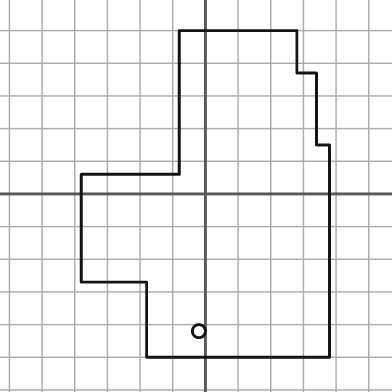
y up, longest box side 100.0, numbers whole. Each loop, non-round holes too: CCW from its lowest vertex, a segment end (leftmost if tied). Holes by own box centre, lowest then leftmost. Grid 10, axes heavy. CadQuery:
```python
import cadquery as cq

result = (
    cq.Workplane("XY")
    .moveTo(-18.0, -50.0)
    .lineTo(38.0, -50.0)
    .lineTo(38.0, 15.0)
    .lineTo(34.0, 15.0)
    .lineTo(34.0, 37.0)
    .lineTo(28.0, 37.0)
    .lineTo(28.0, 50.0)
    .lineTo(-8.0, 50.0)
    .lineTo(-8.0, 6.0)
    .lineTo(-38.0, 6.0)
    .lineTo(-38.0, -27.0)
    .lineTo(-18.0, -27.0)
    .close()
    .moveTo(-2.0, -42.0)
    .circle(2.0)
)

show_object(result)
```